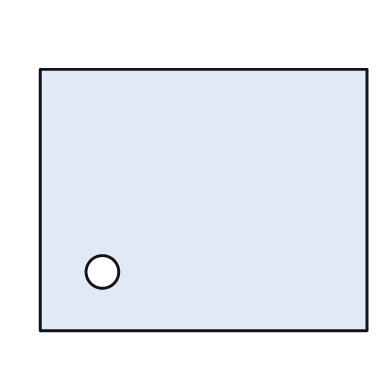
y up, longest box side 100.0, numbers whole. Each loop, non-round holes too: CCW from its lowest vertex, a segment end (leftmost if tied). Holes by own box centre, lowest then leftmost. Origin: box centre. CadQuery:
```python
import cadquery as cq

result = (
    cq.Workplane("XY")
    .moveTo(-50.0, -40.0)
    .lineTo(50.0, -40.0)
    .lineTo(50.0, 40.0)
    .lineTo(-50.0, 40.0)
    .close()
    .moveTo(-31.0, -22.0)
    .circle(5.0)
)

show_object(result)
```